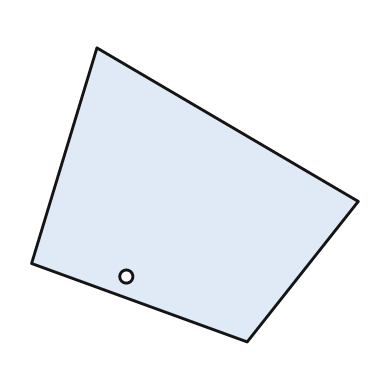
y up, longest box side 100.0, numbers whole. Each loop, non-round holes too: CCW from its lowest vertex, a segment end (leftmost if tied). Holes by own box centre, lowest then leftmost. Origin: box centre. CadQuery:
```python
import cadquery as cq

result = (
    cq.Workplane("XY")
    .moveTo(16.0, -45.0)
    .lineTo(50.0, -2.0)
    .lineTo(-30.0, 45.0)
    .lineTo(-50.0, -21.0)
    .close()
    .moveTo(-21.0, -25.0)
    .circle(2.0)
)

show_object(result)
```